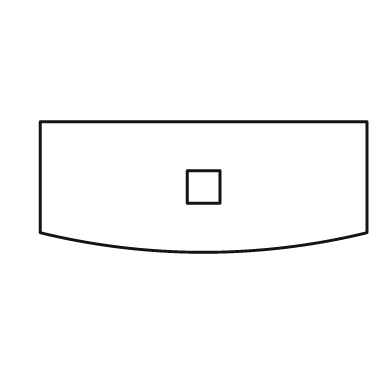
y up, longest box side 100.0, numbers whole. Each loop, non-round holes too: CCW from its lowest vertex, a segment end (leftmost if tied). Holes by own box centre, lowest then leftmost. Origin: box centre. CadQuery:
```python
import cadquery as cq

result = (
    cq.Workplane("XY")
    .moveTo(-50.0, -14.0)
    .threePointArc((0.0, -20.0), (50.0, -14.0))
    .lineTo(50.0, 20.0)
    .lineTo(-50.0, 20.0)
    .close()
    .moveTo(-5.0, -5.0)
    .lineTo(5.0, -5.0)
    .lineTo(5.0, 5.0)
    .lineTo(-5.0, 5.0)
    .close()
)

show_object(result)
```